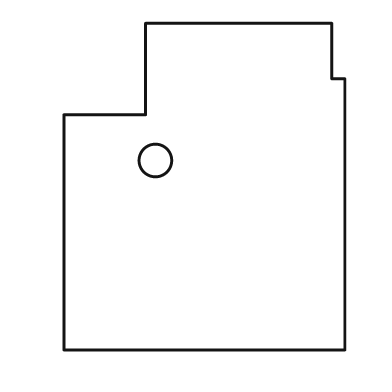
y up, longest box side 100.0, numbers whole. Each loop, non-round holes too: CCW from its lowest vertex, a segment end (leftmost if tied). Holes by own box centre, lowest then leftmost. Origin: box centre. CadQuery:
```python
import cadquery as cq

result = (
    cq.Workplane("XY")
    .moveTo(-43.0, -50.0)
    .lineTo(43.0, -50.0)
    .lineTo(43.0, 33.0)
    .lineTo(39.0, 33.0)
    .lineTo(39.0, 50.0)
    .lineTo(-18.0, 50.0)
    .lineTo(-18.0, 22.0)
    .lineTo(-43.0, 22.0)
    .close()
    .moveTo(-15.0, 8.0)
    .circle(5.0)
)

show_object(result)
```